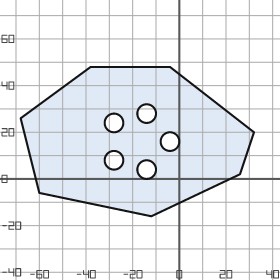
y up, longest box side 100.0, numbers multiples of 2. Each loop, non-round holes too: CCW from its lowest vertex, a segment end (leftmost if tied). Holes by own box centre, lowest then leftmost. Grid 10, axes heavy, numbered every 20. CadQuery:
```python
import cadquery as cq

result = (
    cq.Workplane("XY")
    .moveTo(-12.0, -16.0)
    .lineTo(26.0, 2.0)
    .lineTo(32.0, 20.0)
    .lineTo(-4.0, 48.0)
    .lineTo(-38.0, 48.0)
    .lineTo(-68.0, 26.0)
    .lineTo(-60.0, -6.0)
    .close()
    .moveTo(-14.0, 4.0)
    .circle(4.0)
    .moveTo(-28.0, 8.0)
    .circle(4.0)
    .moveTo(-4.0, 16.0)
    .circle(4.0)
    .moveTo(-28.0, 24.0)
    .circle(4.0)
    .moveTo(-14.0, 28.0)
    .circle(4.0)
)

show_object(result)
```